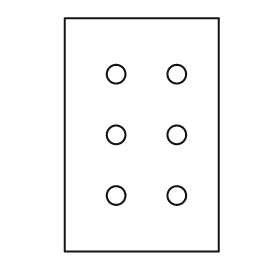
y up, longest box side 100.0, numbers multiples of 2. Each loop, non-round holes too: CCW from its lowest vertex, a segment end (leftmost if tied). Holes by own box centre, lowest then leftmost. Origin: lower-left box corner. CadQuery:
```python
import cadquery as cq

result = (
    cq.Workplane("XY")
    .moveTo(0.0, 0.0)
    .lineTo(66.0, 0.0)
    .lineTo(66.0, 100.0)
    .lineTo(0.0, 100.0)
    .close()
    .moveTo(22.0, 24.0)
    .circle(4.0)
    .moveTo(48.0, 24.0)
    .circle(4.0)
    .moveTo(22.0, 50.0)
    .circle(4.0)
    .moveTo(48.0, 50.0)
    .circle(4.0)
    .moveTo(22.0, 76.0)
    .circle(4.0)
    .moveTo(48.0, 76.0)
    .circle(4.0)
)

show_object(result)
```